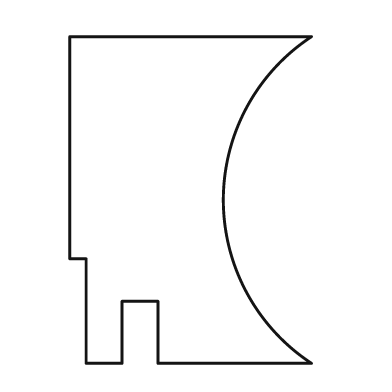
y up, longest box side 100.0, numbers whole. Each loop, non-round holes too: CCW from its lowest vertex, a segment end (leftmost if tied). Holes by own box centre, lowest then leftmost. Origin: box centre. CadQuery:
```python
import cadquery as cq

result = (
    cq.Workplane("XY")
    .moveTo(-32.0, -50.0)
    .lineTo(-21.0, -50.0)
    .lineTo(-21.0, -31.0)
    .lineTo(-10.0, -31.0)
    .lineTo(-10.0, -50.0)
    .lineTo(37.0, -50.0)
    .threePointArc((10.0, 0.0), (37.0, 50.0))
    .lineTo(-37.0, 50.0)
    .lineTo(-37.0, -18.0)
    .lineTo(-32.0, -18.0)
    .close()
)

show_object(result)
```